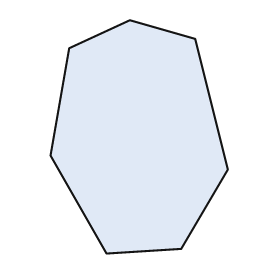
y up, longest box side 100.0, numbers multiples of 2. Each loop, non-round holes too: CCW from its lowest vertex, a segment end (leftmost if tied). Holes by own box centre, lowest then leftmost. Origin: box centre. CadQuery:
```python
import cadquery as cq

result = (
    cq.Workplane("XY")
    .moveTo(-14.0, -50.0)
    .lineTo(18.0, -48.0)
    .lineTo(38.0, -14.0)
    .lineTo(24.0, 42.0)
    .lineTo(-4.0, 50.0)
    .lineTo(-30.0, 38.0)
    .lineTo(-38.0, -8.0)
    .close()
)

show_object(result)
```